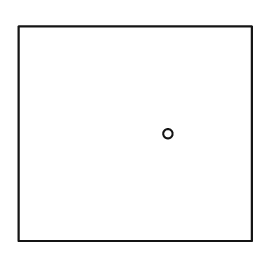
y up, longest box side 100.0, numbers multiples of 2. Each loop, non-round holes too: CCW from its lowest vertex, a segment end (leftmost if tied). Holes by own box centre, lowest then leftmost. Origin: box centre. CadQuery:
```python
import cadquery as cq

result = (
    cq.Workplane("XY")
    .moveTo(-50.0, -46.0)
    .lineTo(50.0, -46.0)
    .lineTo(50.0, 46.0)
    .lineTo(-50.0, 46.0)
    .close()
    .moveTo(14.0, 0.0)
    .circle(2.0)
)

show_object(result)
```